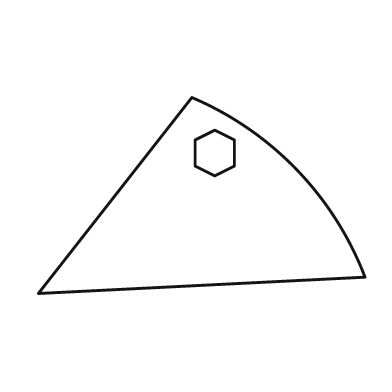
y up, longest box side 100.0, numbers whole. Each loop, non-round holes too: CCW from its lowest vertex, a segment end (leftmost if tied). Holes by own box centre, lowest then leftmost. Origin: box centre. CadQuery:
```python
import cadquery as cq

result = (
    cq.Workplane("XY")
    .moveTo(-50.0, -30.0)
    .lineTo(50.0, -25.0)
    .threePointArc((29.0, 8.0), (-3.0, 30.0))
    .close()
    .moveTo(4.0, 6.0)
    .lineTo(10.0, 9.0)
    .lineTo(10.0, 17.0)
    .lineTo(4.0, 20.0)
    .lineTo(-2.0, 17.0)
    .lineTo(-2.0, 9.0)
    .close()
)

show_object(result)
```